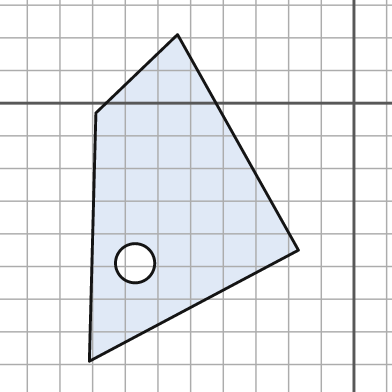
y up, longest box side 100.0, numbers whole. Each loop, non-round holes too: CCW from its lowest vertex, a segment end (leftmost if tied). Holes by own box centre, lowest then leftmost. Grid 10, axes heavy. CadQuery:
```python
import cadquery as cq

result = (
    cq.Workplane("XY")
    .moveTo(-81.0, -79.0)
    .lineTo(-17.0, -45.0)
    .lineTo(-54.0, 21.0)
    .lineTo(-79.0, -3.0)
    .close()
    .moveTo(-67.0, -49.0)
    .circle(6.0)
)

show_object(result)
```